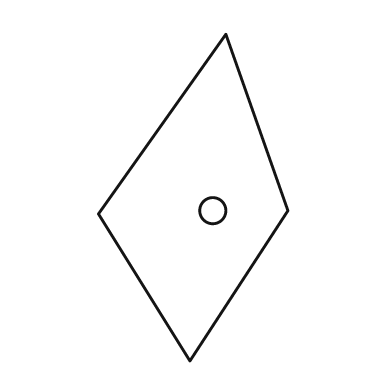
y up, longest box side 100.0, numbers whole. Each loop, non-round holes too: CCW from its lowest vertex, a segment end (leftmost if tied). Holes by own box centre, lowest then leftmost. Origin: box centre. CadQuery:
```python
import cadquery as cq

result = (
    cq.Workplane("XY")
    .moveTo(-1.0, -50.0)
    .lineTo(29.0, -4.0)
    .lineTo(10.0, 50.0)
    .lineTo(-29.0, -5.0)
    .close()
    .moveTo(6.0, -4.0)
    .circle(4.0)
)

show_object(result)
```